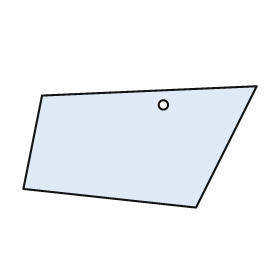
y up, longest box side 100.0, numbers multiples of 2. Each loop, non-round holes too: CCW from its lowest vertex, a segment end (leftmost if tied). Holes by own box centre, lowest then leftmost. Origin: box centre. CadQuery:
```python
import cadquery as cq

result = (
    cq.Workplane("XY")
    .moveTo(24.0, -26.0)
    .lineTo(50.0, 26.0)
    .lineTo(-42.0, 22.0)
    .lineTo(-50.0, -18.0)
    .close()
    .moveTo(10.0, 18.0)
    .circle(2.0)
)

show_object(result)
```